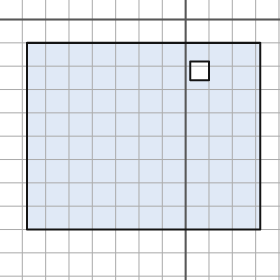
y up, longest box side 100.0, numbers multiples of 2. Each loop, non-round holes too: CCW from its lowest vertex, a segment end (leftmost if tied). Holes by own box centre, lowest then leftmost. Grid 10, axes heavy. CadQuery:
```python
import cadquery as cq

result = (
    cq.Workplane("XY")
    .moveTo(-68.0, -90.0)
    .lineTo(32.0, -90.0)
    .lineTo(32.0, -10.0)
    .lineTo(-68.0, -10.0)
    .close()
    .moveTo(2.0, -26.0)
    .lineTo(10.0, -26.0)
    .lineTo(10.0, -18.0)
    .lineTo(2.0, -18.0)
    .close()
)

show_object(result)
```